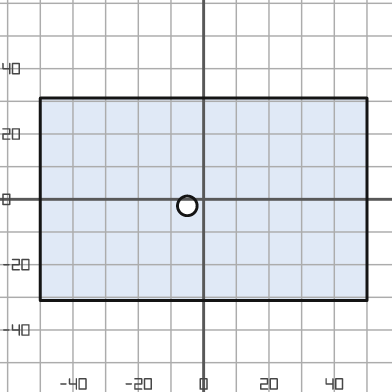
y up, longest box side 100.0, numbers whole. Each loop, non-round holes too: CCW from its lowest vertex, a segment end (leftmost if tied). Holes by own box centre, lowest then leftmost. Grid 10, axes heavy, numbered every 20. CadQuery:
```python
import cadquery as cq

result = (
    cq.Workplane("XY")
    .moveTo(-50.0, -31.0)
    .lineTo(50.0, -31.0)
    .lineTo(50.0, 31.0)
    .lineTo(-50.0, 31.0)
    .close()
    .moveTo(-5.0, -2.0)
    .circle(3.0)
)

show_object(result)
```